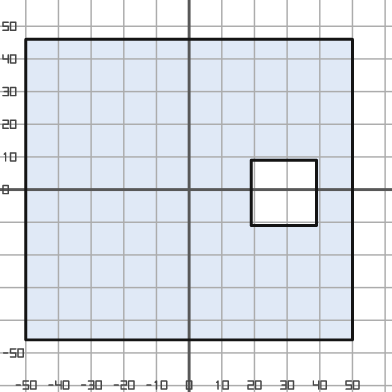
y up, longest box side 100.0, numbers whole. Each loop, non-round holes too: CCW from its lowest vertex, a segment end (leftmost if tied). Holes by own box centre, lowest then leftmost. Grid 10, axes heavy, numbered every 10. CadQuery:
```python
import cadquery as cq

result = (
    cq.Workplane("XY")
    .moveTo(-50.0, -46.0)
    .lineTo(50.0, -46.0)
    .lineTo(50.0, 46.0)
    .lineTo(-50.0, 46.0)
    .close()
    .moveTo(19.0, -11.0)
    .lineTo(39.0, -11.0)
    .lineTo(39.0, 9.0)
    .lineTo(19.0, 9.0)
    .close()
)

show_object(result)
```